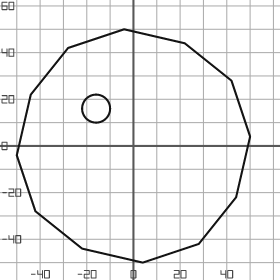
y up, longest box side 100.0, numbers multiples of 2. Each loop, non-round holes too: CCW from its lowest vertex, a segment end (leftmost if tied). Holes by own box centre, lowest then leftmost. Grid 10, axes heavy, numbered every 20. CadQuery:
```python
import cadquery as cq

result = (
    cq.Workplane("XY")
    .moveTo(4.0, -50.0)
    .lineTo(28.0, -42.0)
    .lineTo(44.0, -22.0)
    .lineTo(50.0, 4.0)
    .lineTo(42.0, 28.0)
    .lineTo(22.0, 44.0)
    .lineTo(-4.0, 50.0)
    .lineTo(-28.0, 42.0)
    .lineTo(-44.0, 22.0)
    .lineTo(-50.0, -4.0)
    .lineTo(-42.0, -28.0)
    .lineTo(-22.0, -44.0)
    .close()
    .moveTo(-16.0, 16.0)
    .circle(6.0)
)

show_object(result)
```